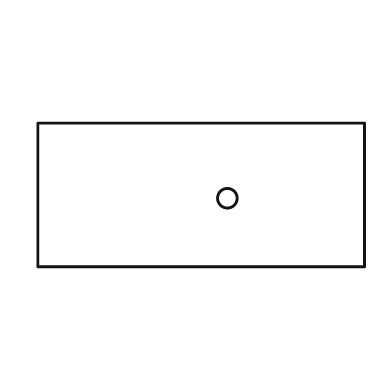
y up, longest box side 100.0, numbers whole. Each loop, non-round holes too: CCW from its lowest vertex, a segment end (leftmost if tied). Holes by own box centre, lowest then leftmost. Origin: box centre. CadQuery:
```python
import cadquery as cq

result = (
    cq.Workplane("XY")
    .moveTo(-50.0, -22.0)
    .lineTo(50.0, -22.0)
    .lineTo(50.0, 22.0)
    .lineTo(-50.0, 22.0)
    .close()
    .moveTo(8.0, -1.0)
    .circle(3.0)
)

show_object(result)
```